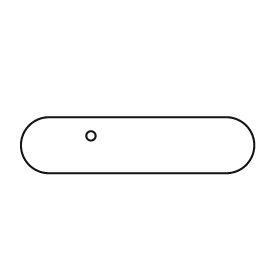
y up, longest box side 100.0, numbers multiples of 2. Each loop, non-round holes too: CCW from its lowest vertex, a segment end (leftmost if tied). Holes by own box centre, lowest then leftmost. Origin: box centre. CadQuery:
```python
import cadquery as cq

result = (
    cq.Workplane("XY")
    .moveTo(-38.0, -12.0)
    .lineTo(38.0, -12.0)
    .threePointArc((50.0, 0.0), (38.0, 12.0))
    .lineTo(-38.0, 12.0)
    .threePointArc((-50.0, 0.0), (-38.0, -12.0))
    .close()
    .moveTo(-20.0, 4.0)
    .circle(2.0)
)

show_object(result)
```